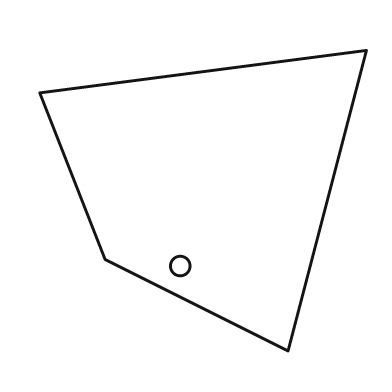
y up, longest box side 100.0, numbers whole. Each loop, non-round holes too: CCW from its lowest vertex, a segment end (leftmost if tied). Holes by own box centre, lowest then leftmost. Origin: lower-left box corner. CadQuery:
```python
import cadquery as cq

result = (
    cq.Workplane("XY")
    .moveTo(76.0, 0.0)
    .lineTo(100.0, 92.0)
    .lineTo(0.0, 79.0)
    .lineTo(20.0, 28.0)
    .close()
    .moveTo(43.0, 26.0)
    .circle(3.0)
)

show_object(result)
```